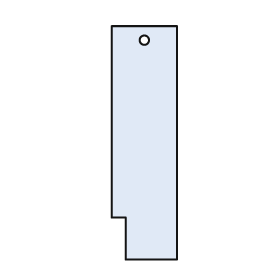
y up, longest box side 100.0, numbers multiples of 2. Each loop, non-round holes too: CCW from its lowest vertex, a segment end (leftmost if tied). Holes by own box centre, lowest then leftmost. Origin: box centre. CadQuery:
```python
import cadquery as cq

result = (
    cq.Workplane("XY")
    .moveTo(-8.0, -50.0)
    .lineTo(14.0, -50.0)
    .lineTo(14.0, 50.0)
    .lineTo(-14.0, 50.0)
    .lineTo(-14.0, -32.0)
    .lineTo(-8.0, -32.0)
    .close()
    .moveTo(0.0, 44.0)
    .circle(2.0)
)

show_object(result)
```